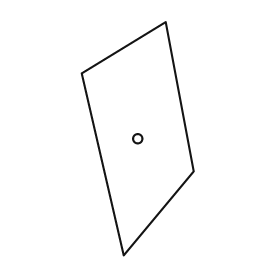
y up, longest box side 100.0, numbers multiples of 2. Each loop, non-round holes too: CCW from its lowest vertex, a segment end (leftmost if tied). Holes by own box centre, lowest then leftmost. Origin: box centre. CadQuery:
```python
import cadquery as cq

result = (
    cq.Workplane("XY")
    .moveTo(-6.0, -50.0)
    .lineTo(24.0, -14.0)
    .lineTo(12.0, 50.0)
    .lineTo(-24.0, 28.0)
    .close()
    .moveTo(0.0, 0.0)
    .circle(2.0)
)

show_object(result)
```